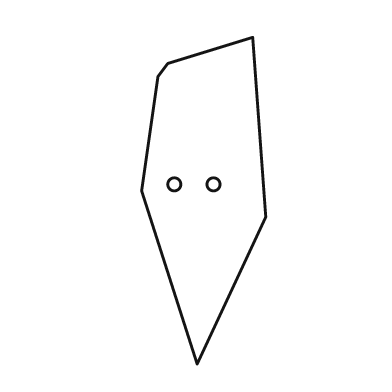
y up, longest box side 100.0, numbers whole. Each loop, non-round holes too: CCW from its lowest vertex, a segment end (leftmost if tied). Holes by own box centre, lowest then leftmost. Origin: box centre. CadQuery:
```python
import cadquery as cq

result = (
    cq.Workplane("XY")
    .moveTo(-2.0, -50.0)
    .lineTo(19.0, -5.0)
    .lineTo(15.0, 50.0)
    .lineTo(-11.0, 42.0)
    .lineTo(-14.0, 38.0)
    .lineTo(-19.0, 3.0)
    .close()
    .moveTo(-9.0, 5.0)
    .circle(2.0)
    .moveTo(3.0, 5.0)
    .circle(2.0)
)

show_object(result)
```